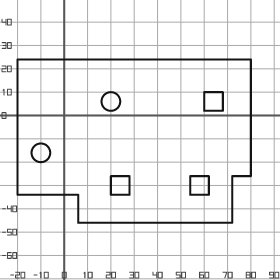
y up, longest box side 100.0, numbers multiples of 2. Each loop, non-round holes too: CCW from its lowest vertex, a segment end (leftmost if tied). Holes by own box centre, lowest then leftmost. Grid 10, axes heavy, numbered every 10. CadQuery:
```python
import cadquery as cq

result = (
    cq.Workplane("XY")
    .moveTo(6.0, -46.0)
    .lineTo(72.0, -46.0)
    .lineTo(72.0, -26.0)
    .lineTo(80.0, -26.0)
    .lineTo(80.0, 24.0)
    .lineTo(-20.0, 24.0)
    .lineTo(-20.0, -34.0)
    .lineTo(6.0, -34.0)
    .close()
    .moveTo(20.0, -34.0)
    .lineTo(28.0, -34.0)
    .lineTo(28.0, -26.0)
    .lineTo(20.0, -26.0)
    .close()
    .moveTo(54.0, -34.0)
    .lineTo(62.0, -34.0)
    .lineTo(62.0, -26.0)
    .lineTo(54.0, -26.0)
    .close()
    .moveTo(-10.0, -16.0)
    .circle(4.0)
    .moveTo(20.0, 6.0)
    .circle(4.0)
    .moveTo(60.0, 2.0)
    .lineTo(68.0, 2.0)
    .lineTo(68.0, 10.0)
    .lineTo(60.0, 10.0)
    .close()
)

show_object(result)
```